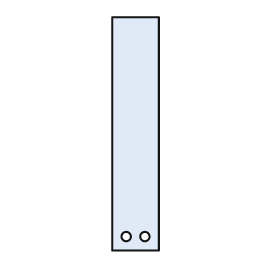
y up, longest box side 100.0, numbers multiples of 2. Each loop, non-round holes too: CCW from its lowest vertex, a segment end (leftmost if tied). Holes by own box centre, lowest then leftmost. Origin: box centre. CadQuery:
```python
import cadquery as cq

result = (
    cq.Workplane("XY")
    .moveTo(-10.0, -50.0)
    .lineTo(10.0, -50.0)
    .lineTo(10.0, 50.0)
    .lineTo(-10.0, 50.0)
    .close()
    .moveTo(-4.0, -44.0)
    .circle(2.0)
    .moveTo(4.0, -44.0)
    .circle(2.0)
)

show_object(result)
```